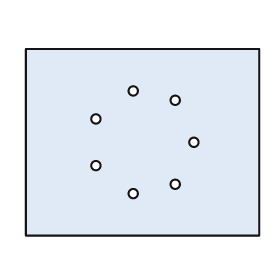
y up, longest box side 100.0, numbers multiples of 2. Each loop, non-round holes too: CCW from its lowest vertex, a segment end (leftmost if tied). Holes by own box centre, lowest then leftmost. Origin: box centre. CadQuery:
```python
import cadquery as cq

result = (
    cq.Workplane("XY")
    .moveTo(-50.0, -40.0)
    .lineTo(50.0, -40.0)
    .lineTo(50.0, 40.0)
    .lineTo(-50.0, 40.0)
    .close()
    .moveTo(-4.0, -22.0)
    .circle(2.0)
    .moveTo(14.0, -18.0)
    .circle(2.0)
    .moveTo(-20.0, -10.0)
    .circle(2.0)
    .moveTo(22.0, 0.0)
    .circle(2.0)
    .moveTo(-20.0, 10.0)
    .circle(2.0)
    .moveTo(14.0, 18.0)
    .circle(2.0)
    .moveTo(-4.0, 22.0)
    .circle(2.0)
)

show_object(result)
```